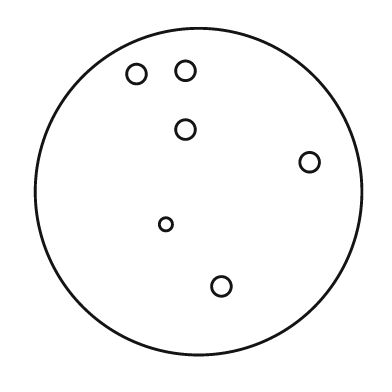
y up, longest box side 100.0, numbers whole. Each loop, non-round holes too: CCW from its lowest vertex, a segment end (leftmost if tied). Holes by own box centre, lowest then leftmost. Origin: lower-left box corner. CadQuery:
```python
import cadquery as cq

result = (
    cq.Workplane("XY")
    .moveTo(50.0, 50.0)
    .circle(50.0)
    .moveTo(57.0, 21.0)
    .circle(3.0)
    .moveTo(40.0, 40.0)
    .circle(2.0)
    .moveTo(84.0, 59.0)
    .circle(3.0)
    .moveTo(46.0, 69.0)
    .circle(3.0)
    .moveTo(31.0, 86.0)
    .circle(3.0)
    .moveTo(46.0, 87.0)
    .circle(3.0)
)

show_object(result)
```